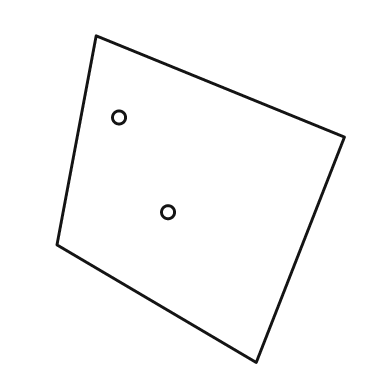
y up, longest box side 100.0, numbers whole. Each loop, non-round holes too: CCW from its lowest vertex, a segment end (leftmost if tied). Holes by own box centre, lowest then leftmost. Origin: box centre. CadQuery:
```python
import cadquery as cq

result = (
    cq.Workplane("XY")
    .moveTo(17.0, -50.0)
    .lineTo(44.0, 19.0)
    .lineTo(-32.0, 50.0)
    .lineTo(-44.0, -14.0)
    .close()
    .moveTo(-10.0, -4.0)
    .circle(2.0)
    .moveTo(-25.0, 25.0)
    .circle(2.0)
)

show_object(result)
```